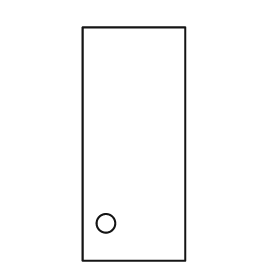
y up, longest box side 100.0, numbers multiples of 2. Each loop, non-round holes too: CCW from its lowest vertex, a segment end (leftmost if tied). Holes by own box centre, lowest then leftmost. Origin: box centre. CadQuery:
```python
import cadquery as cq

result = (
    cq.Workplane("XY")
    .moveTo(-22.0, -50.0)
    .lineTo(22.0, -50.0)
    .lineTo(22.0, 50.0)
    .lineTo(-22.0, 50.0)
    .close()
    .moveTo(-12.0, -34.0)
    .circle(4.0)
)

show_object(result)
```